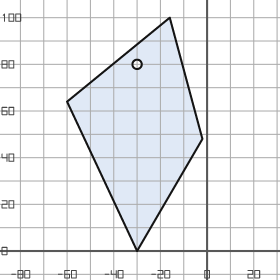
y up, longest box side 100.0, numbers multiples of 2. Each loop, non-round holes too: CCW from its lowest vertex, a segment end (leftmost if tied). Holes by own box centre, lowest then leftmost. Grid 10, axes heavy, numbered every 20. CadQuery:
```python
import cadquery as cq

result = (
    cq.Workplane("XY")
    .moveTo(-30.0, 0.0)
    .lineTo(-2.0, 48.0)
    .lineTo(-16.0, 100.0)
    .lineTo(-60.0, 64.0)
    .close()
    .moveTo(-30.0, 80.0)
    .circle(2.0)
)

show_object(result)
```